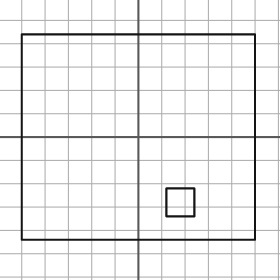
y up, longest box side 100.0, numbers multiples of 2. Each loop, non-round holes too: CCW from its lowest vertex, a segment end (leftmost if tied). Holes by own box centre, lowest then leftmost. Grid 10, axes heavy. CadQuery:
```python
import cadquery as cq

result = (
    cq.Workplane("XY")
    .moveTo(-50.0, -44.0)
    .lineTo(50.0, -44.0)
    .lineTo(50.0, 44.0)
    .lineTo(-50.0, 44.0)
    .close()
    .moveTo(12.0, -34.0)
    .lineTo(24.0, -34.0)
    .lineTo(24.0, -22.0)
    .lineTo(12.0, -22.0)
    .close()
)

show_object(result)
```